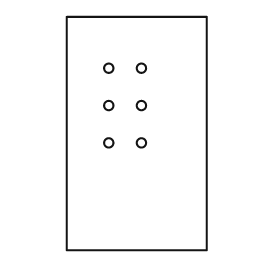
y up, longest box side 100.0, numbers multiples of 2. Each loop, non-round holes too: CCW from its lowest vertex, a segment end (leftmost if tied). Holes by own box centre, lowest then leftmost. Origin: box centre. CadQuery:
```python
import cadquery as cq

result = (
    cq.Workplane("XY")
    .moveTo(-30.0, -50.0)
    .lineTo(30.0, -50.0)
    .lineTo(30.0, 50.0)
    .lineTo(-30.0, 50.0)
    .close()
    .moveTo(-12.0, -4.0)
    .circle(2.0)
    .moveTo(2.0, -4.0)
    .circle(2.0)
    .moveTo(-12.0, 12.0)
    .circle(2.0)
    .moveTo(2.0, 12.0)
    .circle(2.0)
    .moveTo(-12.0, 28.0)
    .circle(2.0)
    .moveTo(2.0, 28.0)
    .circle(2.0)
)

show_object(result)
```